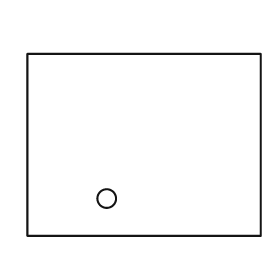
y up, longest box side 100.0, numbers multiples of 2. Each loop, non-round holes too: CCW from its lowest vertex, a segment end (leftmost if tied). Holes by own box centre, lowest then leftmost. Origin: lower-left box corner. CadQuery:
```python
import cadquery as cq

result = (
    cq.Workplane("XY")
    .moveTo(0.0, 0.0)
    .lineTo(100.0, 0.0)
    .lineTo(100.0, 78.0)
    .lineTo(0.0, 78.0)
    .close()
    .moveTo(34.0, 16.0)
    .circle(4.0)
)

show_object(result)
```